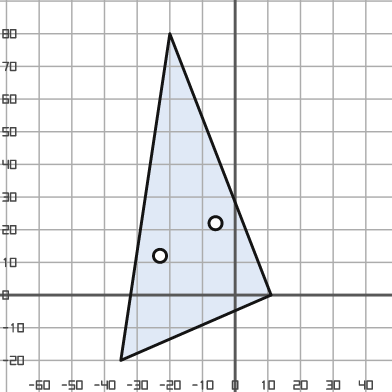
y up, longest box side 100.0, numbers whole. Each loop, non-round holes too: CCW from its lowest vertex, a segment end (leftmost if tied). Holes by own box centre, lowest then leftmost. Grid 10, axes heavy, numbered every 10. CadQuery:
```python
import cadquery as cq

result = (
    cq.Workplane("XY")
    .moveTo(-35.0, -20.0)
    .lineTo(11.0, 0.0)
    .lineTo(-20.0, 80.0)
    .close()
    .moveTo(-23.0, 12.0)
    .circle(2.0)
    .moveTo(-6.0, 22.0)
    .circle(2.0)
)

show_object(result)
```